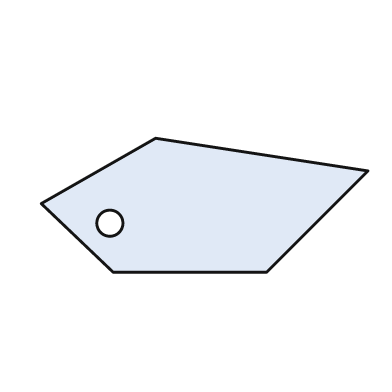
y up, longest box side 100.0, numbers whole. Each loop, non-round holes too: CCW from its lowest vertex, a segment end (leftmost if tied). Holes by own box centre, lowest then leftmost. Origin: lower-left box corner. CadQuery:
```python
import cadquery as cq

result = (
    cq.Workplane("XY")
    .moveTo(22.0, 0.0)
    .lineTo(69.0, 0.0)
    .lineTo(100.0, 31.0)
    .lineTo(35.0, 41.0)
    .lineTo(0.0, 21.0)
    .close()
    .moveTo(21.0, 15.0)
    .circle(4.0)
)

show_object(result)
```